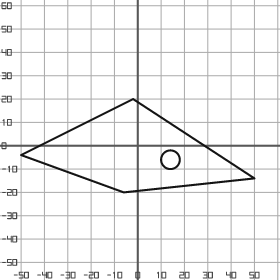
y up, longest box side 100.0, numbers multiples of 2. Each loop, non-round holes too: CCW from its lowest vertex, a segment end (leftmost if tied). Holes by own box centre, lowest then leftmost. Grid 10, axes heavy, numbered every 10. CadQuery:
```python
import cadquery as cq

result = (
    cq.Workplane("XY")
    .moveTo(-6.0, -20.0)
    .lineTo(50.0, -14.0)
    .lineTo(-2.0, 20.0)
    .lineTo(-50.0, -4.0)
    .close()
    .moveTo(14.0, -6.0)
    .circle(4.0)
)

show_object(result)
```